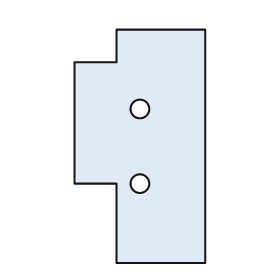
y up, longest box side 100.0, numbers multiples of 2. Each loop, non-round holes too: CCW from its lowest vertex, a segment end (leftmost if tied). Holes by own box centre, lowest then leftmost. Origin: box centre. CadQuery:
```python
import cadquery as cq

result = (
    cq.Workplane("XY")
    .moveTo(-10.0, -50.0)
    .lineTo(28.0, -50.0)
    .lineTo(28.0, 50.0)
    .lineTo(-10.0, 50.0)
    .lineTo(-10.0, 36.0)
    .lineTo(-28.0, 36.0)
    .lineTo(-28.0, -16.0)
    .lineTo(-10.0, -16.0)
    .close()
    .moveTo(0.0, -16.0)
    .circle(4.0)
    .moveTo(0.0, 16.0)
    .circle(4.0)
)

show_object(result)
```